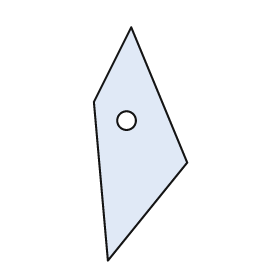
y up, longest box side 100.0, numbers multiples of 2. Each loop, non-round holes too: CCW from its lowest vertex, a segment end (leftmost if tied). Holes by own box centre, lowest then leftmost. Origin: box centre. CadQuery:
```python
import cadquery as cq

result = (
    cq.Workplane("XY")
    .moveTo(-14.0, -50.0)
    .lineTo(20.0, -8.0)
    .lineTo(-4.0, 50.0)
    .lineTo(-20.0, 18.0)
    .close()
    .moveTo(-6.0, 10.0)
    .circle(4.0)
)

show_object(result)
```